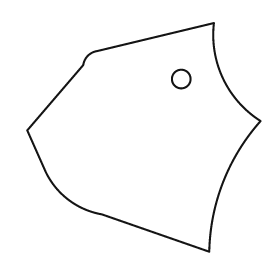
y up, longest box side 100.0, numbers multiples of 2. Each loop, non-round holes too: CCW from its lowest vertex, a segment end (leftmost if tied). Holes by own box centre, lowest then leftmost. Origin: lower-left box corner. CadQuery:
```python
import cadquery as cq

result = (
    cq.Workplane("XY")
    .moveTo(78.0, 0.0)
    .threePointArc((84.0, 30.0), (100.0, 56.0))
    .threePointArc((84.0, 74.0), (80.0, 98.0))
    .lineTo(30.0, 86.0)
    .threePointArc((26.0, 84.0), (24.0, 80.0))
    .lineTo(0.0, 52.0)
    .lineTo(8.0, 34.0)
    .threePointArc((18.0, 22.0), (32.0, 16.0))
    .close()
    .moveTo(66.0, 74.0)
    .circle(4.0)
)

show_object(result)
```